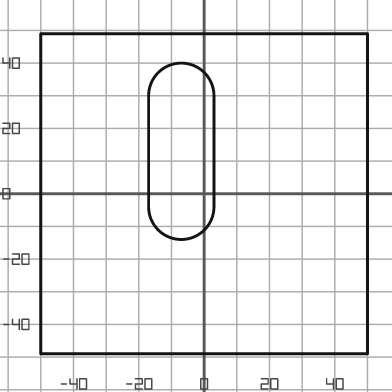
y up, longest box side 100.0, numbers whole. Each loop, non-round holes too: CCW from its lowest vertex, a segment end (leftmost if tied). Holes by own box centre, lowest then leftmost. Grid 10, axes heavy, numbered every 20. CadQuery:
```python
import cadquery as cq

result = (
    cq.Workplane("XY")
    .moveTo(-50.0, -49.0)
    .lineTo(50.0, -49.0)
    .lineTo(50.0, 49.0)
    .lineTo(-50.0, 49.0)
    .close()
    .moveTo(-17.0, -4.0)
    .threePointArc((-7.0, -14.0), (3.0, -4.0))
    .lineTo(3.0, 30.0)
    .threePointArc((-7.0, 40.0), (-17.0, 30.0))
    .close()
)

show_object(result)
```